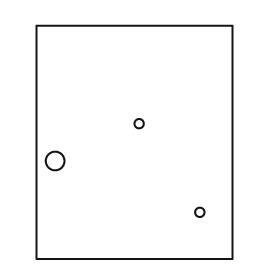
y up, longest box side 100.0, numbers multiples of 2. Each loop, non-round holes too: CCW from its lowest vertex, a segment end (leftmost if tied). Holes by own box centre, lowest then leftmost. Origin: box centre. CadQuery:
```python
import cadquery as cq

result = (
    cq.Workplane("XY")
    .moveTo(-42.0, -50.0)
    .lineTo(42.0, -50.0)
    .lineTo(42.0, 50.0)
    .lineTo(-42.0, 50.0)
    .close()
    .moveTo(28.0, -30.0)
    .circle(2.0)
    .moveTo(-34.0, -8.0)
    .circle(4.0)
    .moveTo(2.0, 8.0)
    .circle(2.0)
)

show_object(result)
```